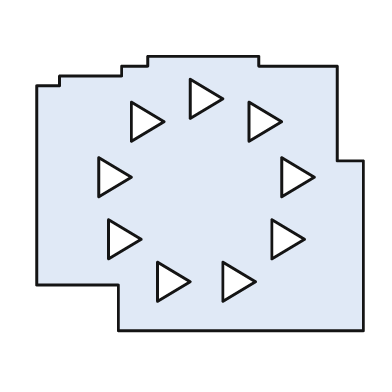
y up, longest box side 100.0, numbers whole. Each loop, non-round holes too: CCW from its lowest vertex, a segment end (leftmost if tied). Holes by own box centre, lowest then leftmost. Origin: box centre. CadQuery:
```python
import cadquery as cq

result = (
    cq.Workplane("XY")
    .moveTo(-25.0, -42.0)
    .lineTo(50.0, -42.0)
    .lineTo(50.0, 10.0)
    .lineTo(42.0, 10.0)
    .lineTo(42.0, 39.0)
    .lineTo(18.0, 39.0)
    .lineTo(18.0, 42.0)
    .lineTo(-16.0, 42.0)
    .lineTo(-16.0, 39.0)
    .lineTo(-24.0, 39.0)
    .lineTo(-24.0, 36.0)
    .lineTo(-43.0, 36.0)
    .lineTo(-43.0, 33.0)
    .lineTo(-50.0, 33.0)
    .lineTo(-50.0, -28.0)
    .lineTo(-25.0, -28.0)
    .close()
    .moveTo(-13.0, -33.0)
    .lineTo(-3.0, -27.0)
    .lineTo(-13.0, -21.0)
    .close()
    .moveTo(7.0, -33.0)
    .lineTo(17.0, -27.0)
    .lineTo(7.0, -21.0)
    .close()
    .moveTo(-28.0, -20.0)
    .lineTo(-18.0, -14.0)
    .lineTo(-28.0, -8.0)
    .close()
    .moveTo(22.0, -20.0)
    .lineTo(32.0, -14.0)
    .lineTo(22.0, -8.0)
    .close()
    .moveTo(-31.0, -1.0)
    .lineTo(-21.0, 5.0)
    .lineTo(-31.0, 11.0)
    .close()
    .moveTo(25.0, -1.0)
    .lineTo(35.0, 5.0)
    .lineTo(25.0, 11.0)
    .close()
    .moveTo(-21.0, 16.0)
    .lineTo(-11.0, 22.0)
    .lineTo(-21.0, 28.0)
    .close()
    .moveTo(15.0, 16.0)
    .lineTo(25.0, 22.0)
    .lineTo(15.0, 28.0)
    .close()
    .moveTo(-3.0, 23.0)
    .lineTo(7.0, 29.0)
    .lineTo(-3.0, 35.0)
    .close()
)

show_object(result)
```